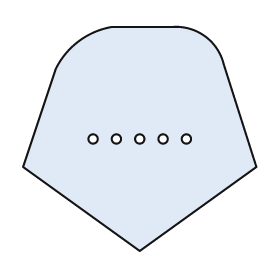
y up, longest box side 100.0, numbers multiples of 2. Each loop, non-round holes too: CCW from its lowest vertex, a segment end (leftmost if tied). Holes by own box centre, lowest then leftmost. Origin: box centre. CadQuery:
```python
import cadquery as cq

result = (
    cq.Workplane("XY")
    .moveTo(0.0, -48.0)
    .lineTo(50.0, -12.0)
    .lineTo(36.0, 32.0)
    .threePointArc((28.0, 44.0), (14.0, 48.0))
    .lineTo(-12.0, 48.0)
    .threePointArc((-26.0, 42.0), (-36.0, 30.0))
    .lineTo(-50.0, -12.0)
    .close()
    .moveTo(-20.0, 0.0)
    .circle(2.0)
    .moveTo(-10.0, 0.0)
    .circle(2.0)
    .moveTo(0.0, 0.0)
    .circle(2.0)
    .moveTo(10.0, 0.0)
    .circle(2.0)
    .moveTo(20.0, 0.0)
    .circle(2.0)
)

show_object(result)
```